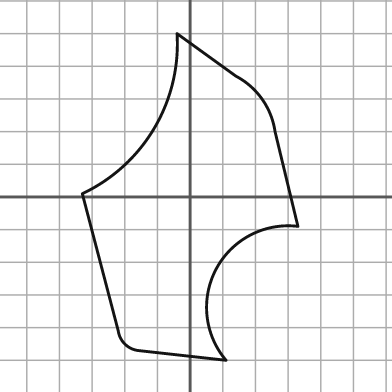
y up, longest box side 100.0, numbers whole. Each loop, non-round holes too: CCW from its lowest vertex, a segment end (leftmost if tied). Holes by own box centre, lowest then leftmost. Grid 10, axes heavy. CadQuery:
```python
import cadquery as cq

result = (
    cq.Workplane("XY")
    .moveTo(11.0, -50.0)
    .threePointArc((8.0, -22.0), (33.0, -9.0))
    .lineTo(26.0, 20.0)
    .threePointArc((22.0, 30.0), (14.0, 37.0))
    .lineTo(-4.0, 50.0)
    .threePointArc((-11.0, 21.0), (-33.0, 1.0))
    .lineTo(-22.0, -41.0)
    .threePointArc((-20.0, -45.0), (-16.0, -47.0))
    .close()
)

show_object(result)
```